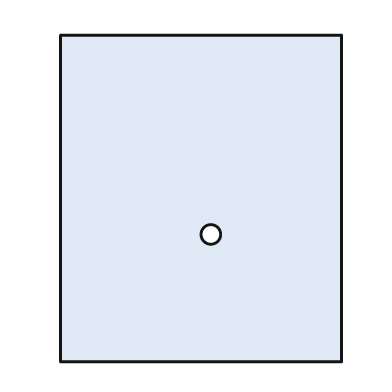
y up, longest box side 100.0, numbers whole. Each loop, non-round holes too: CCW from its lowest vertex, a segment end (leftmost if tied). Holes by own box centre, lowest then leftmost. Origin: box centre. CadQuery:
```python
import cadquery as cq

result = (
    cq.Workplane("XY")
    .moveTo(-43.0, -50.0)
    .lineTo(43.0, -50.0)
    .lineTo(43.0, 50.0)
    .lineTo(-43.0, 50.0)
    .close()
    .moveTo(3.0, -11.0)
    .circle(3.0)
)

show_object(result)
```